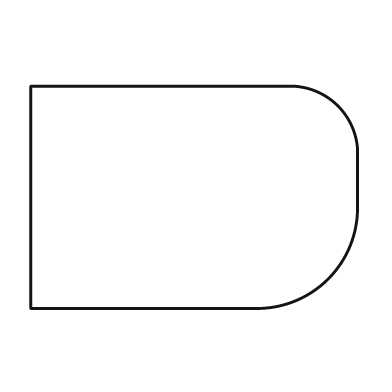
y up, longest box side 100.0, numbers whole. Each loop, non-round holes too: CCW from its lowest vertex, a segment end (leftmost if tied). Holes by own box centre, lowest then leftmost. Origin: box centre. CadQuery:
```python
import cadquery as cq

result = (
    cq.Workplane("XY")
    .moveTo(-50.0, -34.0)
    .lineTo(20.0, -34.0)
    .threePointArc((41.0, -25.0), (50.0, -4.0))
    .lineTo(50.0, 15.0)
    .threePointArc((44.0, 28.0), (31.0, 34.0))
    .lineTo(-50.0, 34.0)
    .close()
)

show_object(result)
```